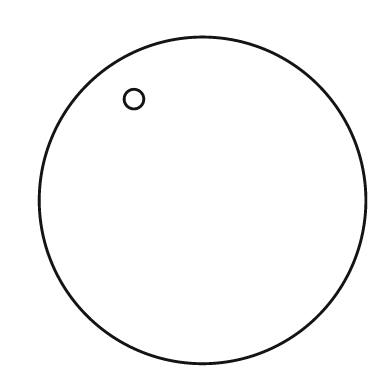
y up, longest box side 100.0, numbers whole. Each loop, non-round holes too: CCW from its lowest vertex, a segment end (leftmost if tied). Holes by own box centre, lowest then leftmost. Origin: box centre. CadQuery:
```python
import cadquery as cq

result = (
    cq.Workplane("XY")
    .moveTo(0.0, 0.0)
    .circle(50.0)
    .moveTo(-21.0, 31.0)
    .circle(3.0)
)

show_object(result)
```